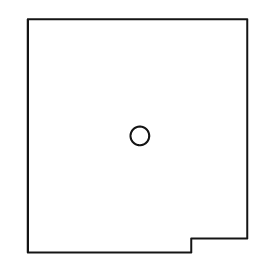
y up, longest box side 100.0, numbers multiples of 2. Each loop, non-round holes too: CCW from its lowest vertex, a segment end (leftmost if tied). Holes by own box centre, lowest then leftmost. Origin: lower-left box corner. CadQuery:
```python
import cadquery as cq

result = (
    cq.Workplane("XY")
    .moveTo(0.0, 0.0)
    .lineTo(70.0, 0.0)
    .lineTo(70.0, 6.0)
    .lineTo(94.0, 6.0)
    .lineTo(94.0, 100.0)
    .lineTo(0.0, 100.0)
    .close()
    .moveTo(48.0, 50.0)
    .circle(4.0)
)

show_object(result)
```